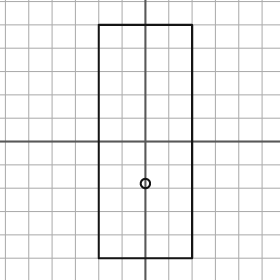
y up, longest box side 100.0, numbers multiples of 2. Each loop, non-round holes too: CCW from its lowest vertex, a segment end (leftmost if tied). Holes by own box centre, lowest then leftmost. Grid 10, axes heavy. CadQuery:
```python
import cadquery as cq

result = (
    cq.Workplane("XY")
    .moveTo(-20.0, -50.0)
    .lineTo(20.0, -50.0)
    .lineTo(20.0, 50.0)
    .lineTo(-20.0, 50.0)
    .close()
    .moveTo(0.0, -18.0)
    .circle(2.0)
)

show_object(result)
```